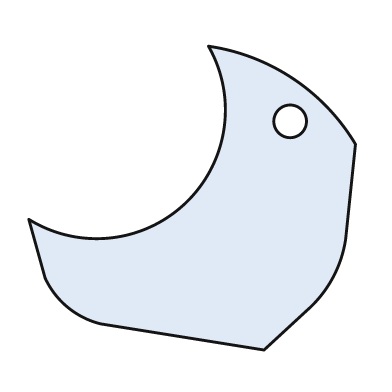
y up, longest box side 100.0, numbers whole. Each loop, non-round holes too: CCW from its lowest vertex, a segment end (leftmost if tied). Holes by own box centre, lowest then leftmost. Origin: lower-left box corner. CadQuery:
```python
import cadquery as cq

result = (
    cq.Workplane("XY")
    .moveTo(72.0, 0.0)
    .lineTo(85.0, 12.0)
    .threePointArc((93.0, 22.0), (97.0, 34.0))
    .lineTo(100.0, 63.0)
    .threePointArc((81.0, 83.0), (55.0, 93.0))
    .threePointArc((48.0, 45.0), (0.0, 40.0))
    .lineTo(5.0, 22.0)
    .threePointArc((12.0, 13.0), (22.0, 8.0))
    .close()
    .moveTo(80.0, 70.0)
    .circle(5.0)
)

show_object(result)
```